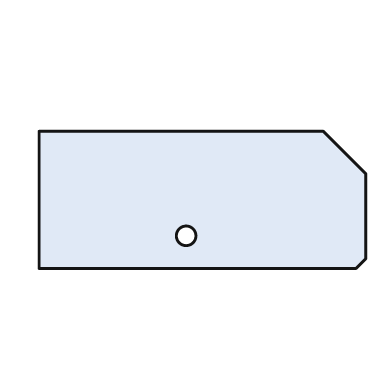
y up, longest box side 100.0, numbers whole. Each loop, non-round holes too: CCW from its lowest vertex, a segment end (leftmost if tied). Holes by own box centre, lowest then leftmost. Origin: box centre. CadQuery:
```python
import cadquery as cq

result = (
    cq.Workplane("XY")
    .moveTo(-50.0, -21.0)
    .lineTo(47.0, -21.0)
    .lineTo(50.0, -18.0)
    .lineTo(50.0, 8.0)
    .lineTo(37.0, 21.0)
    .lineTo(-50.0, 21.0)
    .close()
    .moveTo(-5.0, -11.0)
    .circle(3.0)
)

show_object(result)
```